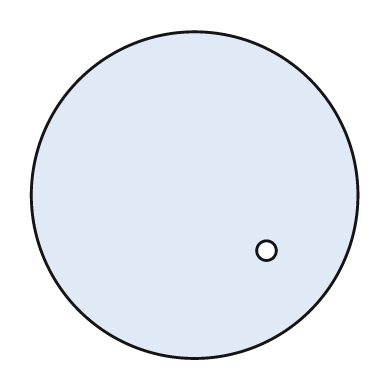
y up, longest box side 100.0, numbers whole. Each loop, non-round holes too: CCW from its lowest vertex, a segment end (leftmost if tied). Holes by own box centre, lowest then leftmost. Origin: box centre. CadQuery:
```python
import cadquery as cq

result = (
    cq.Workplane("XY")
    .moveTo(0.0, 0.0)
    .circle(50.0)
    .moveTo(22.0, -17.0)
    .circle(3.0)
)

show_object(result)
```